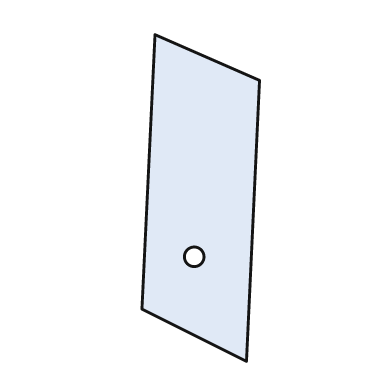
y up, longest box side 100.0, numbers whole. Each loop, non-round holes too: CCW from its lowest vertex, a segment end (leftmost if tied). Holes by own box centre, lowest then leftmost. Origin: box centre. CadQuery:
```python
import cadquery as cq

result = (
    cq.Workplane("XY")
    .moveTo(14.0, -50.0)
    .lineTo(18.0, 36.0)
    .lineTo(-14.0, 50.0)
    .lineTo(-18.0, -34.0)
    .close()
    .moveTo(-2.0, -18.0)
    .circle(3.0)
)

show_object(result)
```